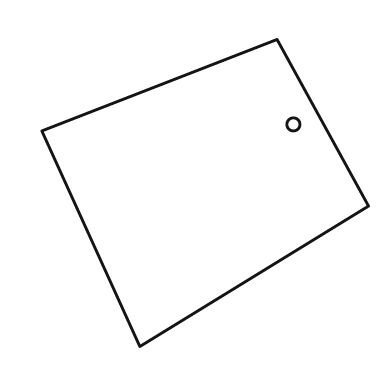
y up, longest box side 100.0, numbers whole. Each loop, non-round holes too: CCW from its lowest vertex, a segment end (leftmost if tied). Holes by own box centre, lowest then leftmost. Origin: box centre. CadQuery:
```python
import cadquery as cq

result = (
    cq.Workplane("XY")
    .moveTo(-20.0, -47.0)
    .lineTo(50.0, -4.0)
    .lineTo(22.0, 47.0)
    .lineTo(-50.0, 19.0)
    .close()
    .moveTo(27.0, 21.0)
    .circle(2.0)
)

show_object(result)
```